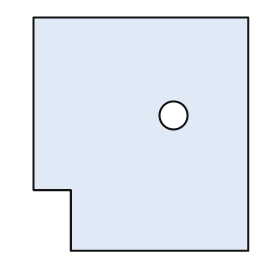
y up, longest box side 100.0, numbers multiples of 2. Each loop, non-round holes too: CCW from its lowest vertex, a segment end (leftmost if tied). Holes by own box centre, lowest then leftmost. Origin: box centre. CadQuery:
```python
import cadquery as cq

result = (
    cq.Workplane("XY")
    .moveTo(-30.0, -50.0)
    .lineTo(46.0, -50.0)
    .lineTo(46.0, 50.0)
    .lineTo(-46.0, 50.0)
    .lineTo(-46.0, -24.0)
    .lineTo(-30.0, -24.0)
    .close()
    .moveTo(14.0, 8.0)
    .circle(6.0)
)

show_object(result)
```